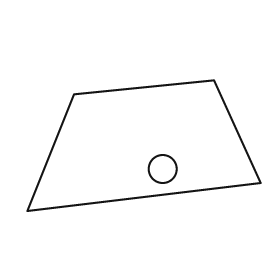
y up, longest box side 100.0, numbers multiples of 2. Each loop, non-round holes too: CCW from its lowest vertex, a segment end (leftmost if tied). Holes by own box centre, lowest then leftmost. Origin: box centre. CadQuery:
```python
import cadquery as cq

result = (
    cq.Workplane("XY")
    .moveTo(-50.0, -28.0)
    .lineTo(50.0, -16.0)
    .lineTo(30.0, 28.0)
    .lineTo(-30.0, 22.0)
    .close()
    .moveTo(8.0, -10.0)
    .circle(6.0)
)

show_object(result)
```